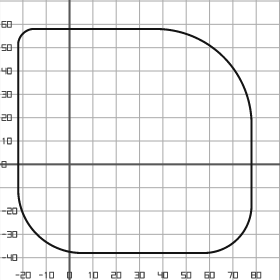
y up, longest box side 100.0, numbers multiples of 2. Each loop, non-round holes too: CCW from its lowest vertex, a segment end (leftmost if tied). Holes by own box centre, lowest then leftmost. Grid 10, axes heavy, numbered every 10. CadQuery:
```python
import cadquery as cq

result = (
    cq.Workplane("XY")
    .moveTo(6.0, -38.0)
    .lineTo(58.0, -38.0)
    .threePointArc((72.0, -32.0), (78.0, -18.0))
    .lineTo(78.0, 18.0)
    .threePointArc((66.0, 46.0), (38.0, 58.0))
    .lineTo(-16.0, 58.0)
    .threePointArc((-20.0, 56.0), (-22.0, 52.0))
    .lineTo(-22.0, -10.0)
    .threePointArc((-14.0, -30.0), (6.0, -38.0))
    .close()
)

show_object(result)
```